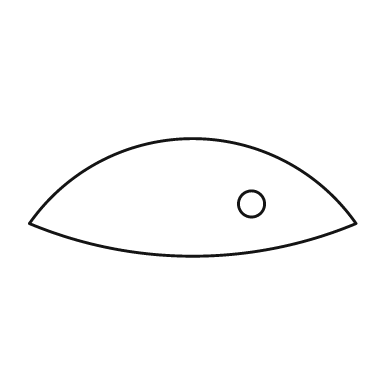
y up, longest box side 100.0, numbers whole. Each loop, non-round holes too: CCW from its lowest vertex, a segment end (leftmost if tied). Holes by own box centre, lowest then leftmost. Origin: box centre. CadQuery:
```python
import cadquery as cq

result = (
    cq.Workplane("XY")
    .moveTo(-50.0, -8.0)
    .threePointArc((0.0, -18.0), (50.0, -8.0))
    .threePointArc((0.0, 18.0), (-50.0, -8.0))
    .close()
    .moveTo(18.0, -2.0)
    .circle(4.0)
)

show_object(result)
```